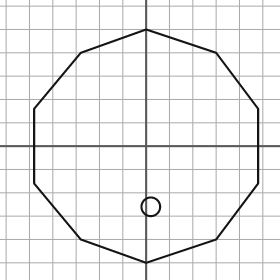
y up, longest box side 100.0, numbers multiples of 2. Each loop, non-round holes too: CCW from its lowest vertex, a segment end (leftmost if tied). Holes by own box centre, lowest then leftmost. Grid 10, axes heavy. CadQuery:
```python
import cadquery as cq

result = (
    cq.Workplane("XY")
    .moveTo(0.0, -50.0)
    .lineTo(30.0, -40.0)
    .lineTo(48.0, -16.0)
    .lineTo(48.0, 16.0)
    .lineTo(30.0, 40.0)
    .lineTo(0.0, 50.0)
    .lineTo(-28.0, 40.0)
    .lineTo(-48.0, 16.0)
    .lineTo(-48.0, -16.0)
    .lineTo(-28.0, -40.0)
    .close()
    .moveTo(2.0, -26.0)
    .circle(4.0)
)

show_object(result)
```